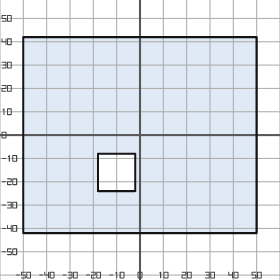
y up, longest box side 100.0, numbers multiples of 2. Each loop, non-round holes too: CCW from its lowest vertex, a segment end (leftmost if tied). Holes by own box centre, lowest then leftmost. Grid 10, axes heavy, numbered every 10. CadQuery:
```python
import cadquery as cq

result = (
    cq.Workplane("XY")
    .moveTo(-50.0, -42.0)
    .lineTo(50.0, -42.0)
    .lineTo(50.0, 42.0)
    .lineTo(-50.0, 42.0)
    .close()
    .moveTo(-18.0, -24.0)
    .lineTo(-2.0, -24.0)
    .lineTo(-2.0, -8.0)
    .lineTo(-18.0, -8.0)
    .close()
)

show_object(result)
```